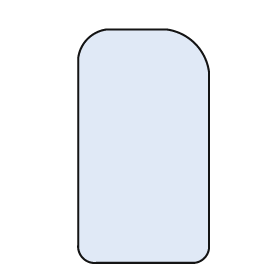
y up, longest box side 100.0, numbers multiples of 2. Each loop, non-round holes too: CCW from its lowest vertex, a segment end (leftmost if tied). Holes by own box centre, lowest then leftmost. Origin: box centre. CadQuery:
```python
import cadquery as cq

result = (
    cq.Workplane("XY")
    .moveTo(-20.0, -50.0)
    .lineTo(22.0, -50.0)
    .threePointArc((26.0, -48.0), (28.0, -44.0))
    .lineTo(28.0, 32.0)
    .threePointArc((22.0, 44.0), (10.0, 50.0))
    .lineTo(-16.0, 50.0)
    .threePointArc((-24.0, 46.0), (-28.0, 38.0))
    .lineTo(-28.0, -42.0)
    .threePointArc((-26.0, -48.0), (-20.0, -50.0))
    .close()
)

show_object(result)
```